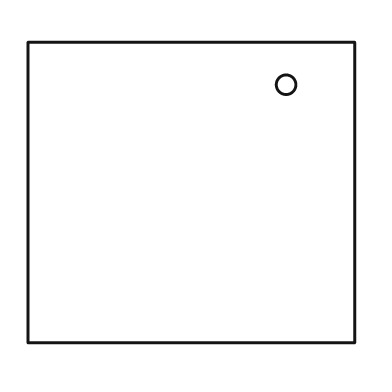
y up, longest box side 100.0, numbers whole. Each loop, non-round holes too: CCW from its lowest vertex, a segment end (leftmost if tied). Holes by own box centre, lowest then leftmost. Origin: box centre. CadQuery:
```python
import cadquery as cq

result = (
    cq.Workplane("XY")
    .moveTo(-50.0, -46.0)
    .lineTo(50.0, -46.0)
    .lineTo(50.0, 46.0)
    .lineTo(-50.0, 46.0)
    .close()
    .moveTo(29.0, 33.0)
    .circle(3.0)
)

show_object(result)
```